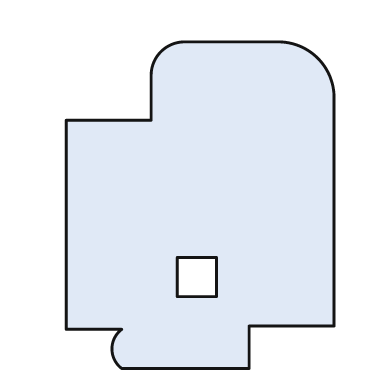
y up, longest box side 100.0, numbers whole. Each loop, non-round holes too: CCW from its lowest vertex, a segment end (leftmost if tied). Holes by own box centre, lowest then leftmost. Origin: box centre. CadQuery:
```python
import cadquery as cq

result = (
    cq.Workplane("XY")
    .moveTo(-24.0, -50.0)
    .lineTo(15.0, -50.0)
    .lineTo(15.0, -37.0)
    .lineTo(41.0, -37.0)
    .lineTo(41.0, 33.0)
    .threePointArc((36.0, 45.0), (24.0, 50.0))
    .lineTo(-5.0, 50.0)
    .threePointArc((-12.0, 47.0), (-15.0, 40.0))
    .lineTo(-15.0, 26.0)
    .lineTo(-41.0, 26.0)
    .lineTo(-41.0, -38.0)
    .lineTo(-24.0, -38.0)
    .threePointArc((-27.0, -44.0), (-24.0, -50.0))
    .close()
    .moveTo(-7.0, -28.0)
    .lineTo(5.0, -28.0)
    .lineTo(5.0, -16.0)
    .lineTo(-7.0, -16.0)
    .close()
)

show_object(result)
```